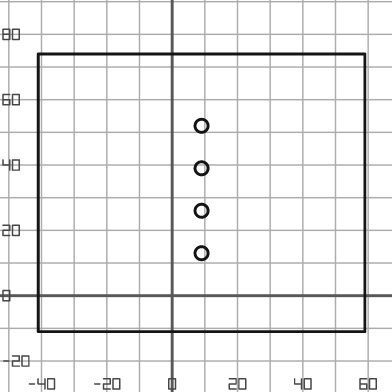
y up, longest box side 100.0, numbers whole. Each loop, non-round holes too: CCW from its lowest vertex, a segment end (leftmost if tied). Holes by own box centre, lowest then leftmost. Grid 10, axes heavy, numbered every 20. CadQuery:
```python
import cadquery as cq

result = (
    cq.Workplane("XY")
    .moveTo(-41.0, -11.0)
    .lineTo(59.0, -11.0)
    .lineTo(59.0, 74.0)
    .lineTo(-41.0, 74.0)
    .close()
    .moveTo(9.0, 13.0)
    .circle(2.0)
    .moveTo(9.0, 26.0)
    .circle(2.0)
    .moveTo(9.0, 39.0)
    .circle(2.0)
    .moveTo(9.0, 52.0)
    .circle(2.0)
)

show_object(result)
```